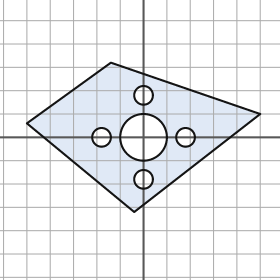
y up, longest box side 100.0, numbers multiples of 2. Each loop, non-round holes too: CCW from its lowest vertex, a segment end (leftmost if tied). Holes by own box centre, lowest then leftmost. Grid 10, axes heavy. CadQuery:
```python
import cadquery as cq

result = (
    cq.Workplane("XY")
    .moveTo(-4.0, -32.0)
    .lineTo(50.0, 10.0)
    .lineTo(-14.0, 32.0)
    .lineTo(-50.0, 6.0)
    .close()
    .moveTo(0.0, -18.0)
    .circle(4.0)
    .moveTo(-18.0, 0.0)
    .circle(4.0)
    .moveTo(0.0, 0.0)
    .circle(10.0)
    .moveTo(18.0, 0.0)
    .circle(4.0)
    .moveTo(0.0, 18.0)
    .circle(4.0)
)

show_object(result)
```